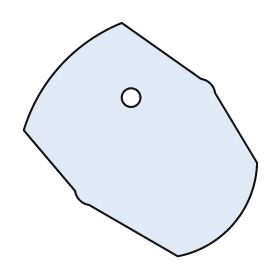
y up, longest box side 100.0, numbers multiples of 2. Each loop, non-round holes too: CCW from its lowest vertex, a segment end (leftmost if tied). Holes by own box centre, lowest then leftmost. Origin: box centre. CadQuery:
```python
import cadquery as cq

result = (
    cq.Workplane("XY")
    .moveTo(16.0, -50.0)
    .threePointArc((40.0, -36.0), (50.0, -10.0))
    .lineTo(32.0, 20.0)
    .threePointArc((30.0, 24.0), (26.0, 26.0))
    .lineTo(-8.0, 50.0)
    .threePointArc((-34.0, 32.0), (-50.0, 4.0))
    .lineTo(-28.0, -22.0)
    .threePointArc((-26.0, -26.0), (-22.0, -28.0))
    .close()
    .moveTo(-4.0, 18.0)
    .circle(4.0)
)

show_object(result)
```